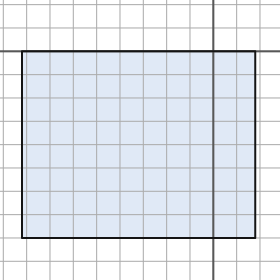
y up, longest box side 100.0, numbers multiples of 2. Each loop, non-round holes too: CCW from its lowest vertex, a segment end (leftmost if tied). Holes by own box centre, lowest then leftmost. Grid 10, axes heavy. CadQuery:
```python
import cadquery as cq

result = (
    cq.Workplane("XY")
    .moveTo(-82.0, -80.0)
    .lineTo(18.0, -80.0)
    .lineTo(18.0, 0.0)
    .lineTo(-82.0, 0.0)
    .close()
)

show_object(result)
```